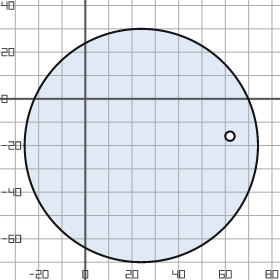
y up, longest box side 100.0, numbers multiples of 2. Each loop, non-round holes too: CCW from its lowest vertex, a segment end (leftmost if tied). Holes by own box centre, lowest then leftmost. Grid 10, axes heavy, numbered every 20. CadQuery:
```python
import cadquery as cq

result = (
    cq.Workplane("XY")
    .moveTo(24.0, -20.0)
    .circle(50.0)
    .moveTo(62.0, -16.0)
    .circle(2.0)
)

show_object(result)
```